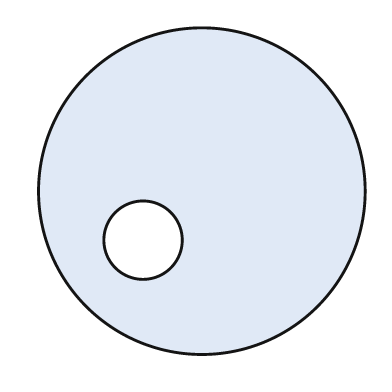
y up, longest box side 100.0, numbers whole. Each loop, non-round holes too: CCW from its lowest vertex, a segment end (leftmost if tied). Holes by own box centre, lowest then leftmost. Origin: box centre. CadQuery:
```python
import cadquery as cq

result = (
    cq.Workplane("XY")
    .moveTo(0.0, 0.0)
    .circle(50.0)
    .moveTo(-18.0, -15.0)
    .circle(12.0)
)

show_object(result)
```